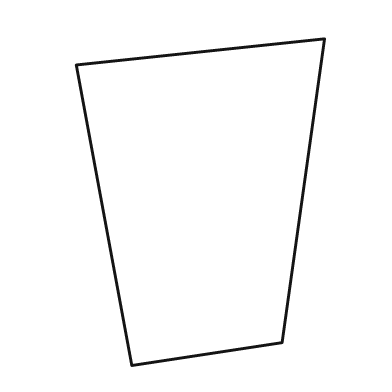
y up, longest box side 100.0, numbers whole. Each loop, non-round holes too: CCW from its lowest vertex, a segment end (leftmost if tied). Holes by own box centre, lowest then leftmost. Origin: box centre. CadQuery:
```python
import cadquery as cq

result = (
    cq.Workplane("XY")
    .moveTo(-21.0, -50.0)
    .lineTo(25.0, -43.0)
    .lineTo(38.0, 50.0)
    .lineTo(-38.0, 42.0)
    .close()
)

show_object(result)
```